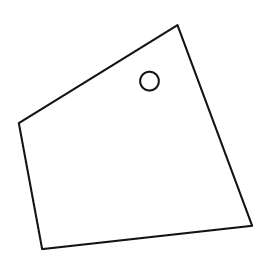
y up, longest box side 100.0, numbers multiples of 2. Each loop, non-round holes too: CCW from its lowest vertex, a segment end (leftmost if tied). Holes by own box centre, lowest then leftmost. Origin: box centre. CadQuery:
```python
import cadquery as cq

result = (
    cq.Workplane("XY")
    .moveTo(-40.0, -48.0)
    .lineTo(50.0, -38.0)
    .lineTo(18.0, 48.0)
    .lineTo(-50.0, 6.0)
    .close()
    .moveTo(6.0, 24.0)
    .circle(4.0)
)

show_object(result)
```